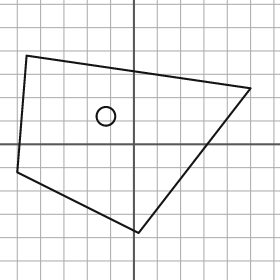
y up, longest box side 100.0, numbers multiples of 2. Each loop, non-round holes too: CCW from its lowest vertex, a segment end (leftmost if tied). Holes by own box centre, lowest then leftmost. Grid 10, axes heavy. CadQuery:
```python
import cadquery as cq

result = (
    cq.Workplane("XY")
    .moveTo(2.0, -38.0)
    .lineTo(50.0, 24.0)
    .lineTo(-46.0, 38.0)
    .lineTo(-50.0, -12.0)
    .close()
    .moveTo(-12.0, 12.0)
    .circle(4.0)
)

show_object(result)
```